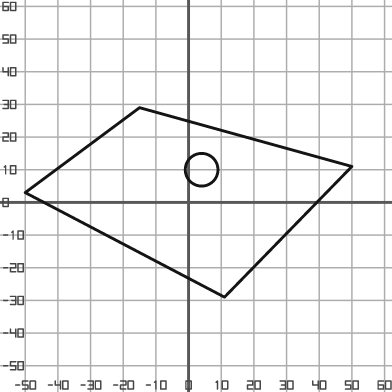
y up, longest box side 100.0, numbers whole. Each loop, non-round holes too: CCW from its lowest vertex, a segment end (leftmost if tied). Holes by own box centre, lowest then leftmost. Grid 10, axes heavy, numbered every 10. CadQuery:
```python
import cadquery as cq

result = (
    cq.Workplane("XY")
    .moveTo(11.0, -29.0)
    .lineTo(50.0, 11.0)
    .lineTo(-15.0, 29.0)
    .lineTo(-50.0, 3.0)
    .close()
    .moveTo(4.0, 10.0)
    .circle(5.0)
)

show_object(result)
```